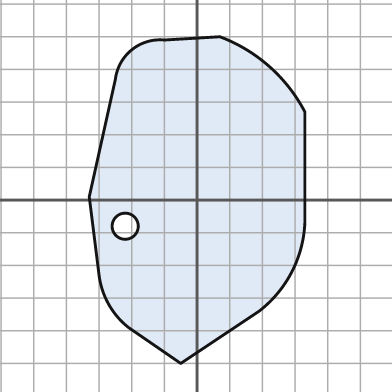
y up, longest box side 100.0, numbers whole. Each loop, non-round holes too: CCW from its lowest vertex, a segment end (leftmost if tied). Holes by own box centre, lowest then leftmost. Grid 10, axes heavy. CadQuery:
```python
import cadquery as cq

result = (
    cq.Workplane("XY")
    .moveTo(-5.0, -50.0)
    .lineTo(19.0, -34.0)
    .threePointArc((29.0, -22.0), (33.0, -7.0))
    .lineTo(33.0, 27.0)
    .threePointArc((22.0, 41.0), (7.0, 50.0))
    .lineTo(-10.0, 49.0)
    .threePointArc((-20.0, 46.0), (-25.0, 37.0))
    .lineTo(-33.0, 1.0)
    .lineTo(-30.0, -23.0)
    .threePointArc((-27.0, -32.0), (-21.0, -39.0))
    .close()
    .moveTo(-22.0, -8.0)
    .circle(4.0)
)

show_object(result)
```